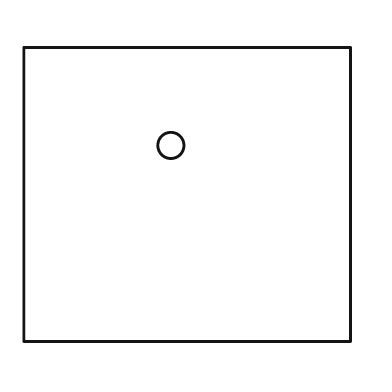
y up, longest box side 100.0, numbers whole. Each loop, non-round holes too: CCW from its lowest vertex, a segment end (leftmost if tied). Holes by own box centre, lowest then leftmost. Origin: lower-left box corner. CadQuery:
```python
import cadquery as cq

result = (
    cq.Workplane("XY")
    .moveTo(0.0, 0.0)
    .lineTo(100.0, 0.0)
    .lineTo(100.0, 90.0)
    .lineTo(0.0, 90.0)
    .close()
    .moveTo(45.0, 60.0)
    .circle(4.0)
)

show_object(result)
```